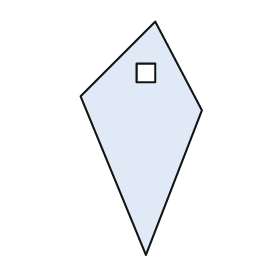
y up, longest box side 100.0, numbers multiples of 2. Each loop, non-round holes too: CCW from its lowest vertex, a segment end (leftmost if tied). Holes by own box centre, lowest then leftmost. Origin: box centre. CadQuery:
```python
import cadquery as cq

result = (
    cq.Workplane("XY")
    .moveTo(2.0, -50.0)
    .lineTo(26.0, 12.0)
    .lineTo(6.0, 50.0)
    .lineTo(-26.0, 18.0)
    .close()
    .moveTo(-2.0, 24.0)
    .lineTo(6.0, 24.0)
    .lineTo(6.0, 32.0)
    .lineTo(-2.0, 32.0)
    .close()
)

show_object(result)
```